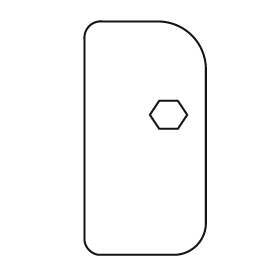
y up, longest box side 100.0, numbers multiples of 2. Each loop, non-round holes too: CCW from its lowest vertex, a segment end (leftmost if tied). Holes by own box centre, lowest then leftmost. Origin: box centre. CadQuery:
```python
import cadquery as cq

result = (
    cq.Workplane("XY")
    .moveTo(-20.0, -50.0)
    .lineTo(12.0, -50.0)
    .threePointArc((22.0, -46.0), (26.0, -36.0))
    .lineTo(26.0, 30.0)
    .threePointArc((20.0, 44.0), (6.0, 50.0))
    .lineTo(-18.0, 50.0)
    .threePointArc((-24.0, 48.0), (-26.0, 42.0))
    .lineTo(-26.0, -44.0)
    .threePointArc((-24.0, -48.0), (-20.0, -50.0))
    .close()
    .moveTo(6.0, 4.0)
    .lineTo(14.0, 4.0)
    .lineTo(18.0, 10.0)
    .lineTo(14.0, 16.0)
    .lineTo(6.0, 16.0)
    .lineTo(2.0, 10.0)
    .close()
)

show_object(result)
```